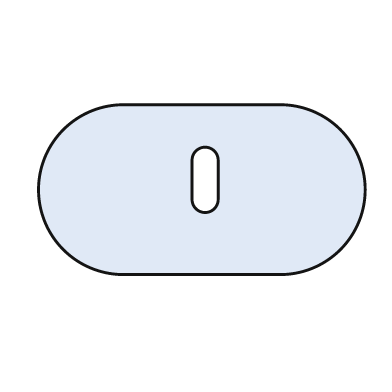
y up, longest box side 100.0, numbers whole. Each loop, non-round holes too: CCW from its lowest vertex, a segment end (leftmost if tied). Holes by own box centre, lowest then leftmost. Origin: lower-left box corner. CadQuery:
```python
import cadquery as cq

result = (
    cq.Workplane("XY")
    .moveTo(26.0, 0.0)
    .lineTo(74.0, 0.0)
    .threePointArc((100.0, 26.0), (74.0, 52.0))
    .lineTo(26.0, 52.0)
    .threePointArc((0.0, 26.0), (26.0, 0.0))
    .close()
    .moveTo(47.0, 23.0)
    .threePointArc((51.0, 19.0), (55.0, 23.0))
    .lineTo(55.0, 35.0)
    .threePointArc((51.0, 39.0), (47.0, 35.0))
    .close()
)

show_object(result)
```